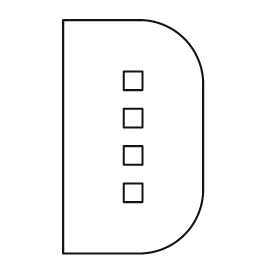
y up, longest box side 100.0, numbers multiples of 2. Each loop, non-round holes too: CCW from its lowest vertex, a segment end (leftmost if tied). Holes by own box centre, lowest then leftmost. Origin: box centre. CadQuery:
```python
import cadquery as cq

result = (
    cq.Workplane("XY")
    .moveTo(-30.0, -50.0)
    .lineTo(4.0, -50.0)
    .threePointArc((22.0, -42.0), (30.0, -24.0))
    .lineTo(30.0, 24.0)
    .threePointArc((22.0, 42.0), (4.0, 50.0))
    .lineTo(-30.0, 50.0)
    .close()
    .moveTo(-4.0, -28.0)
    .lineTo(4.0, -28.0)
    .lineTo(4.0, -20.0)
    .lineTo(-4.0, -20.0)
    .close()
    .moveTo(-4.0, -12.0)
    .lineTo(4.0, -12.0)
    .lineTo(4.0, -4.0)
    .lineTo(-4.0, -4.0)
    .close()
    .moveTo(-4.0, 4.0)
    .lineTo(4.0, 4.0)
    .lineTo(4.0, 12.0)
    .lineTo(-4.0, 12.0)
    .close()
    .moveTo(-4.0, 20.0)
    .lineTo(4.0, 20.0)
    .lineTo(4.0, 28.0)
    .lineTo(-4.0, 28.0)
    .close()
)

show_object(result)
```